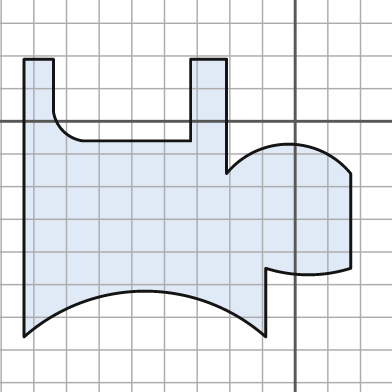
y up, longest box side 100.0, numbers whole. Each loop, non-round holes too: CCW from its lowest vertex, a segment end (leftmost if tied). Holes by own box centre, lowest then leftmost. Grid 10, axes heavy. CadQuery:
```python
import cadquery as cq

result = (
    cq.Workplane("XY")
    .moveTo(-83.0, -66.0)
    .threePointArc((-46.0, -52.0), (-9.0, -66.0))
    .lineTo(-9.0, -45.0)
    .threePointArc((4.0, -47.0), (17.0, -45.0))
    .lineTo(17.0, -16.0)
    .threePointArc((-2.0, -7.0), (-21.0, -16.0))
    .lineTo(-21.0, 19.0)
    .lineTo(-32.0, 19.0)
    .lineTo(-32.0, -6.0)
    .lineTo(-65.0, -6.0)
    .threePointArc((-71.0, -3.0), (-74.0, 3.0))
    .lineTo(-74.0, 19.0)
    .lineTo(-83.0, 19.0)
    .close()
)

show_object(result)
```